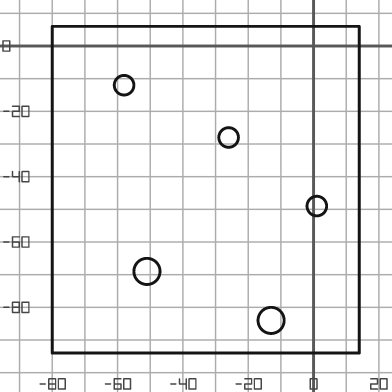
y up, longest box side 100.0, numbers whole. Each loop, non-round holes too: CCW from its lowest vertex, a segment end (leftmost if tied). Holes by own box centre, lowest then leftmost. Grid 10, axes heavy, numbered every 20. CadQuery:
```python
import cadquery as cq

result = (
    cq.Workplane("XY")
    .moveTo(-80.0, -94.0)
    .lineTo(14.0, -94.0)
    .lineTo(14.0, 6.0)
    .lineTo(-80.0, 6.0)
    .close()
    .moveTo(-13.0, -84.0)
    .circle(4.0)
    .moveTo(-51.0, -69.0)
    .circle(4.0)
    .moveTo(1.0, -49.0)
    .circle(3.0)
    .moveTo(-26.0, -28.0)
    .circle(3.0)
    .moveTo(-58.0, -12.0)
    .circle(3.0)
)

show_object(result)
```